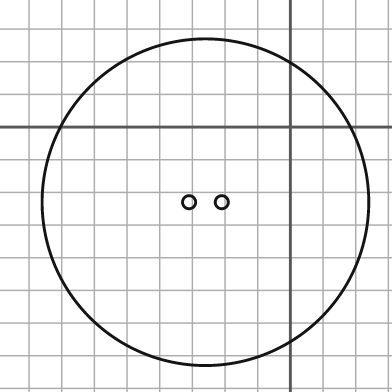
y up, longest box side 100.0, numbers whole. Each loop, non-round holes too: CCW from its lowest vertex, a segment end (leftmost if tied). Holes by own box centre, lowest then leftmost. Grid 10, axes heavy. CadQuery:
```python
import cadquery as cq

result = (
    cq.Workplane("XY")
    .moveTo(-26.0, -23.0)
    .circle(50.0)
    .moveTo(-31.0, -23.0)
    .circle(2.0)
    .moveTo(-21.0, -23.0)
    .circle(2.0)
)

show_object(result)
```